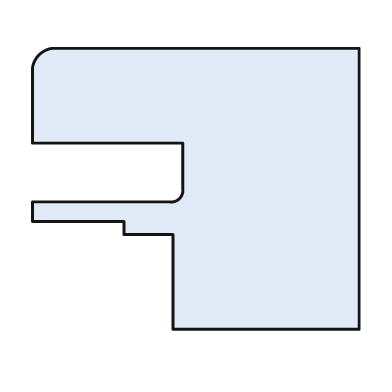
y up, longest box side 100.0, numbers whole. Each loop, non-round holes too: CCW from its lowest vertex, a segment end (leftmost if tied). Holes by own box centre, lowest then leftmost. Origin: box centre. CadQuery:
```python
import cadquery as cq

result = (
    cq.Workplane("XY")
    .moveTo(-7.0, -43.0)
    .lineTo(50.0, -43.0)
    .lineTo(50.0, 43.0)
    .lineTo(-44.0, 43.0)
    .threePointArc((-48.0, 41.0), (-50.0, 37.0))
    .lineTo(-50.0, 14.0)
    .lineTo(-4.0, 14.0)
    .lineTo(-4.0, 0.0)
    .threePointArc((-5.0, -3.0), (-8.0, -4.0))
    .lineTo(-50.0, -4.0)
    .lineTo(-50.0, -10.0)
    .lineTo(-22.0, -10.0)
    .lineTo(-22.0, -14.0)
    .lineTo(-7.0, -14.0)
    .close()
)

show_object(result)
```